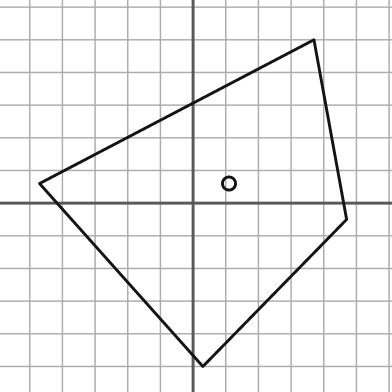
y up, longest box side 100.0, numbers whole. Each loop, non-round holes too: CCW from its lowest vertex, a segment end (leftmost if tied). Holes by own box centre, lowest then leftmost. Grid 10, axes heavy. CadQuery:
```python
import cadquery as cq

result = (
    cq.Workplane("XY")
    .moveTo(3.0, -50.0)
    .lineTo(47.0, -5.0)
    .lineTo(37.0, 50.0)
    .lineTo(-47.0, 6.0)
    .close()
    .moveTo(11.0, 6.0)
    .circle(2.0)
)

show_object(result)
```